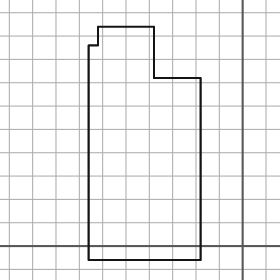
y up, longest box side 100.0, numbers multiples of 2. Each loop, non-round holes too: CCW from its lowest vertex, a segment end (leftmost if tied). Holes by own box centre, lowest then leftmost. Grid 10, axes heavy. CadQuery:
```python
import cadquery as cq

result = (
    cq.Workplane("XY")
    .moveTo(-66.0, -6.0)
    .lineTo(-18.0, -6.0)
    .lineTo(-18.0, 72.0)
    .lineTo(-38.0, 72.0)
    .lineTo(-38.0, 94.0)
    .lineTo(-62.0, 94.0)
    .lineTo(-62.0, 86.0)
    .lineTo(-66.0, 86.0)
    .close()
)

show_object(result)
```